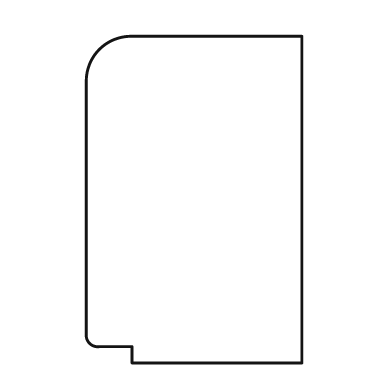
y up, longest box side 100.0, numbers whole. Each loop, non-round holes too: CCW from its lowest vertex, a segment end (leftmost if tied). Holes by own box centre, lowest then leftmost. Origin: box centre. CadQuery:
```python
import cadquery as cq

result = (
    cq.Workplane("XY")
    .moveTo(-19.0, -50.0)
    .lineTo(33.0, -50.0)
    .lineTo(33.0, 50.0)
    .lineTo(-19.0, 50.0)
    .threePointArc((-29.0, 46.0), (-33.0, 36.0))
    .lineTo(-33.0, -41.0)
    .threePointArc((-32.0, -44.0), (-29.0, -45.0))
    .lineTo(-19.0, -45.0)
    .close()
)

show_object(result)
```